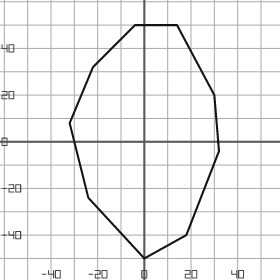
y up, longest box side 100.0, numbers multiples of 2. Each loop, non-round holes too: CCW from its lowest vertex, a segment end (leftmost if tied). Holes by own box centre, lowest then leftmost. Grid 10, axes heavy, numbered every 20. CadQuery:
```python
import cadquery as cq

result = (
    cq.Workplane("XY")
    .moveTo(0.0, -50.0)
    .lineTo(18.0, -40.0)
    .lineTo(32.0, -4.0)
    .lineTo(30.0, 20.0)
    .lineTo(14.0, 50.0)
    .lineTo(-4.0, 50.0)
    .lineTo(-22.0, 32.0)
    .lineTo(-32.0, 8.0)
    .lineTo(-24.0, -24.0)
    .close()
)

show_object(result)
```